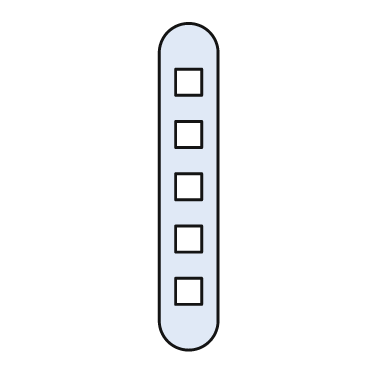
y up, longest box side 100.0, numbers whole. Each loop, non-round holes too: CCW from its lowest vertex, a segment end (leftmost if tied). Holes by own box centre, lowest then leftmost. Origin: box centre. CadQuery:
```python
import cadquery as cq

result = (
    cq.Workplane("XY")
    .moveTo(-9.0, -41.0)
    .threePointArc((0.0, -50.0), (9.0, -41.0))
    .lineTo(9.0, 41.0)
    .threePointArc((0.0, 50.0), (-9.0, 41.0))
    .close()
    .moveTo(-4.0, -36.0)
    .lineTo(4.0, -36.0)
    .lineTo(4.0, -28.0)
    .lineTo(-4.0, -28.0)
    .close()
    .moveTo(-4.0, -20.0)
    .lineTo(4.0, -20.0)
    .lineTo(4.0, -12.0)
    .lineTo(-4.0, -12.0)
    .close()
    .moveTo(-4.0, -4.0)
    .lineTo(4.0, -4.0)
    .lineTo(4.0, 4.0)
    .lineTo(-4.0, 4.0)
    .close()
    .moveTo(-4.0, 12.0)
    .lineTo(4.0, 12.0)
    .lineTo(4.0, 20.0)
    .lineTo(-4.0, 20.0)
    .close()
    .moveTo(-4.0, 28.0)
    .lineTo(4.0, 28.0)
    .lineTo(4.0, 36.0)
    .lineTo(-4.0, 36.0)
    .close()
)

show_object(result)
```